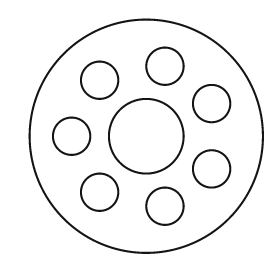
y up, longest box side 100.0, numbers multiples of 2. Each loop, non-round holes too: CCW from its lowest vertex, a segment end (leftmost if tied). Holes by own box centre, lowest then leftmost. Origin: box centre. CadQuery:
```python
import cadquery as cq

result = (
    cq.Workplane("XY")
    .moveTo(0.0, 0.0)
    .circle(50.0)
    .moveTo(8.0, -30.0)
    .circle(8.0)
    .moveTo(-20.0, -24.0)
    .circle(8.0)
    .moveTo(28.0, -14.0)
    .circle(8.0)
    .moveTo(-32.0, 0.0)
    .circle(8.0)
    .moveTo(0.0, 0.0)
    .circle(16.0)
    .moveTo(28.0, 14.0)
    .circle(8.0)
    .moveTo(-20.0, 24.0)
    .circle(8.0)
    .moveTo(8.0, 30.0)
    .circle(8.0)
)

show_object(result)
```